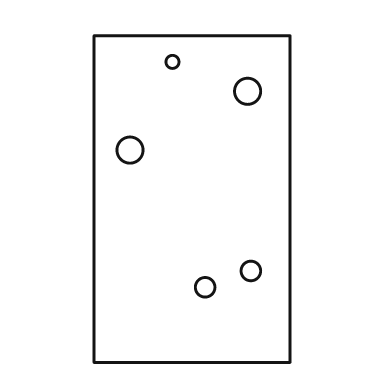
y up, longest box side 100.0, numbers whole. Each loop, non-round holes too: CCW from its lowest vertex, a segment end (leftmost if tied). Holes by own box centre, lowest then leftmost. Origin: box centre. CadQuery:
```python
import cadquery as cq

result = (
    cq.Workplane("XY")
    .moveTo(-30.0, -50.0)
    .lineTo(30.0, -50.0)
    .lineTo(30.0, 50.0)
    .lineTo(-30.0, 50.0)
    .close()
    .moveTo(4.0, -27.0)
    .circle(3.0)
    .moveTo(18.0, -22.0)
    .circle(3.0)
    .moveTo(-19.0, 15.0)
    .circle(4.0)
    .moveTo(17.0, 33.0)
    .circle(4.0)
    .moveTo(-6.0, 42.0)
    .circle(2.0)
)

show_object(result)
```